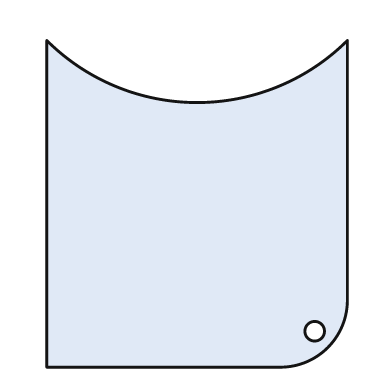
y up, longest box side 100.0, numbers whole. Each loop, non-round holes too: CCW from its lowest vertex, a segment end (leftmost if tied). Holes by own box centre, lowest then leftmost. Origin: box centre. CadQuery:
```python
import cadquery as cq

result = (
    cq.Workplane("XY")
    .moveTo(-46.0, -50.0)
    .lineTo(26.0, -50.0)
    .threePointArc((40.0, -44.0), (46.0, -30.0))
    .lineTo(46.0, 50.0)
    .threePointArc((0.0, 31.0), (-46.0, 50.0))
    .close()
    .moveTo(36.0, -39.0)
    .circle(3.0)
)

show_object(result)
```